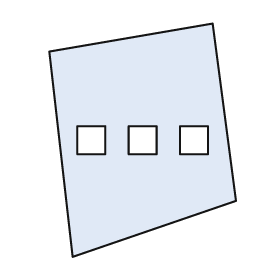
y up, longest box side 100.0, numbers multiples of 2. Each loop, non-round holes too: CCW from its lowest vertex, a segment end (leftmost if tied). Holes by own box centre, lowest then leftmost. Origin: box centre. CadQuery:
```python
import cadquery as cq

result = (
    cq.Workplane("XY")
    .moveTo(-30.0, -50.0)
    .lineTo(40.0, -26.0)
    .lineTo(30.0, 50.0)
    .lineTo(-40.0, 38.0)
    .close()
    .moveTo(-28.0, -6.0)
    .lineTo(-16.0, -6.0)
    .lineTo(-16.0, 6.0)
    .lineTo(-28.0, 6.0)
    .close()
    .moveTo(-6.0, -6.0)
    .lineTo(6.0, -6.0)
    .lineTo(6.0, 6.0)
    .lineTo(-6.0, 6.0)
    .close()
    .moveTo(16.0, -6.0)
    .lineTo(28.0, -6.0)
    .lineTo(28.0, 6.0)
    .lineTo(16.0, 6.0)
    .close()
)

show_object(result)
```